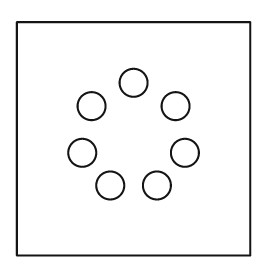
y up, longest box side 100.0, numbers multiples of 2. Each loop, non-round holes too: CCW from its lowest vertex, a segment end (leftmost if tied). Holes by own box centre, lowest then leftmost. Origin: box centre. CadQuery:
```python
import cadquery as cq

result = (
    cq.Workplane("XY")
    .moveTo(-50.0, -50.0)
    .lineTo(50.0, -50.0)
    .lineTo(50.0, 50.0)
    .lineTo(-50.0, 50.0)
    .close()
    .moveTo(-10.0, -20.0)
    .circle(6.0)
    .moveTo(10.0, -20.0)
    .circle(6.0)
    .moveTo(-22.0, -6.0)
    .circle(6.0)
    .moveTo(22.0, -6.0)
    .circle(6.0)
    .moveTo(-18.0, 14.0)
    .circle(6.0)
    .moveTo(18.0, 14.0)
    .circle(6.0)
    .moveTo(0.0, 24.0)
    .circle(6.0)
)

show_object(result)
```